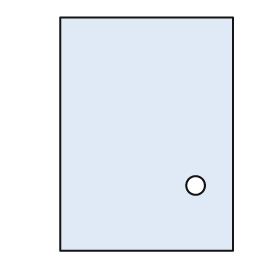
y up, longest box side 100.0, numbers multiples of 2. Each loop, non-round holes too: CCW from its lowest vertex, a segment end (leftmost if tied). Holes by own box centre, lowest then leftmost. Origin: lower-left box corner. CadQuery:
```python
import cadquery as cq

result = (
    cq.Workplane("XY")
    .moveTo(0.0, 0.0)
    .lineTo(74.0, 0.0)
    .lineTo(74.0, 100.0)
    .lineTo(0.0, 100.0)
    .close()
    .moveTo(58.0, 28.0)
    .circle(4.0)
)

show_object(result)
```